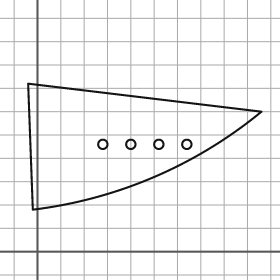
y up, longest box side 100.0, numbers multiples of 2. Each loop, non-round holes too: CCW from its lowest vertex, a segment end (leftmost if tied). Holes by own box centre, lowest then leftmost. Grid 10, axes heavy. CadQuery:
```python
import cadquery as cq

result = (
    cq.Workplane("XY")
    .moveTo(-2.0, 18.0)
    .threePointArc((50.0, 32.0), (96.0, 60.0))
    .lineTo(-4.0, 72.0)
    .close()
    .moveTo(28.0, 46.0)
    .circle(2.0)
    .moveTo(40.0, 46.0)
    .circle(2.0)
    .moveTo(52.0, 46.0)
    .circle(2.0)
    .moveTo(64.0, 46.0)
    .circle(2.0)
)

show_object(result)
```